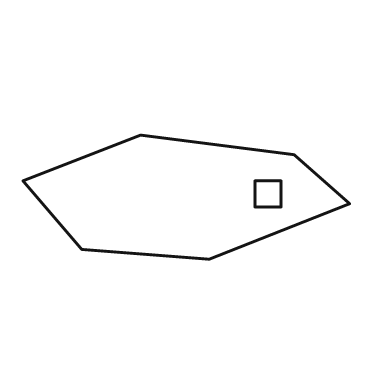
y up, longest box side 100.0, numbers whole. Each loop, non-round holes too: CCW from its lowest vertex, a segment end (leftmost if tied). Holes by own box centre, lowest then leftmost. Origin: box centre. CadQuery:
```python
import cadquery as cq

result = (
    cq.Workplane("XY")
    .moveTo(7.0, -19.0)
    .lineTo(50.0, -2.0)
    .lineTo(33.0, 13.0)
    .lineTo(-14.0, 19.0)
    .lineTo(-50.0, 5.0)
    .lineTo(-32.0, -16.0)
    .close()
    .moveTo(21.0, -3.0)
    .lineTo(29.0, -3.0)
    .lineTo(29.0, 5.0)
    .lineTo(21.0, 5.0)
    .close()
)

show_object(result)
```